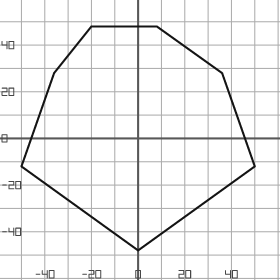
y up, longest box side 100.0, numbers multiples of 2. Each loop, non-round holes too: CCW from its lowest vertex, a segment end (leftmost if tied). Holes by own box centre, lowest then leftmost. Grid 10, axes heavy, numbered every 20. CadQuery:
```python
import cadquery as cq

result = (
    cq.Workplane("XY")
    .moveTo(0.0, -48.0)
    .lineTo(50.0, -12.0)
    .lineTo(36.0, 28.0)
    .lineTo(8.0, 48.0)
    .lineTo(-20.0, 48.0)
    .lineTo(-36.0, 28.0)
    .lineTo(-50.0, -12.0)
    .close()
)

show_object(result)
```